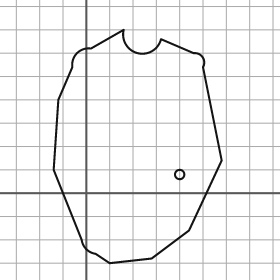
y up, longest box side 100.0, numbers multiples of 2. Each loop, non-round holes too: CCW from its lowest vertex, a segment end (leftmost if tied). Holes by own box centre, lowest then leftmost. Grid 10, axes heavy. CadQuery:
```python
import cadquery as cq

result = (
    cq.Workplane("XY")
    .moveTo(10.0, -30.0)
    .lineTo(28.0, -28.0)
    .lineTo(44.0, -16.0)
    .lineTo(58.0, 14.0)
    .lineTo(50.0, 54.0)
    .threePointArc((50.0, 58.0), (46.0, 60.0))
    .lineTo(32.0, 66.0)
    .threePointArc((22.0, 60.0), (16.0, 70.0))
    .lineTo(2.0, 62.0)
    .threePointArc((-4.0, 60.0), (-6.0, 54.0))
    .lineTo(-12.0, 40.0)
    .lineTo(-14.0, 10.0)
    .lineTo(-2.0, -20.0)
    .threePointArc((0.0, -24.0), (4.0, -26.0))
    .close()
    .moveTo(40.0, 8.0)
    .circle(2.0)
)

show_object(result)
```